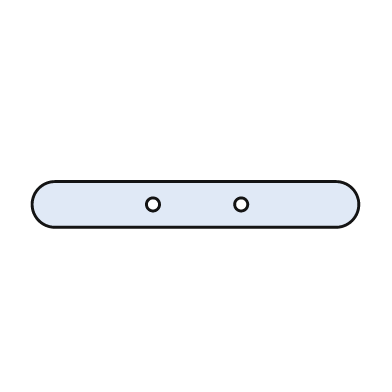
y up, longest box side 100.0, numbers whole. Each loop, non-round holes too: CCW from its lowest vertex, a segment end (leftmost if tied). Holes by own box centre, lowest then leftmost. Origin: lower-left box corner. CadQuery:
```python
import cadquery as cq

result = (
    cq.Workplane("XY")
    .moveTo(7.0, 0.0)
    .lineTo(93.0, 0.0)
    .threePointArc((100.0, 7.0), (93.0, 14.0))
    .lineTo(7.0, 14.0)
    .threePointArc((0.0, 7.0), (7.0, 0.0))
    .close()
    .moveTo(37.0, 7.0)
    .circle(2.0)
    .moveTo(64.0, 7.0)
    .circle(2.0)
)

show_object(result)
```